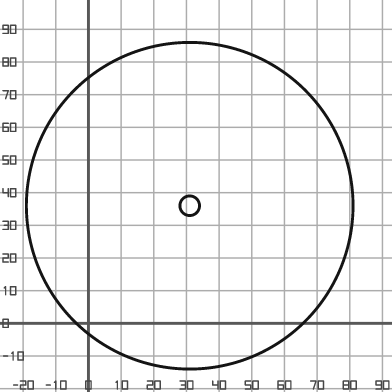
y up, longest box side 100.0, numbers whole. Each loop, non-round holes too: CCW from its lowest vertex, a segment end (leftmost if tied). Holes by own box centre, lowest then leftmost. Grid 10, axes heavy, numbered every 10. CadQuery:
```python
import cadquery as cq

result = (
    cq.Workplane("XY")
    .moveTo(31.0, 36.0)
    .circle(50.0)
    .moveTo(31.0, 36.0)
    .circle(3.0)
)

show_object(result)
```